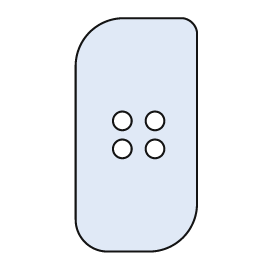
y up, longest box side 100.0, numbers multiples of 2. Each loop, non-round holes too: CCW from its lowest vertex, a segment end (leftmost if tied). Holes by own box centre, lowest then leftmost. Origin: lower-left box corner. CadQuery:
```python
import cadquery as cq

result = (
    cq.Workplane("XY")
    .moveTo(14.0, 0.0)
    .lineTo(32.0, 0.0)
    .threePointArc((46.0, 6.0), (52.0, 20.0))
    .lineTo(52.0, 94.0)
    .threePointArc((50.0, 98.0), (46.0, 100.0))
    .lineTo(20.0, 100.0)
    .threePointArc((6.0, 94.0), (0.0, 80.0))
    .lineTo(0.0, 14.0)
    .threePointArc((4.0, 4.0), (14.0, 0.0))
    .close()
    .moveTo(20.0, 44.0)
    .circle(4.0)
    .moveTo(34.0, 44.0)
    .circle(4.0)
    .moveTo(20.0, 56.0)
    .circle(4.0)
    .moveTo(34.0, 56.0)
    .circle(4.0)
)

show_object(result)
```